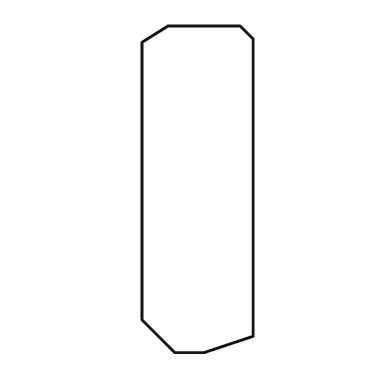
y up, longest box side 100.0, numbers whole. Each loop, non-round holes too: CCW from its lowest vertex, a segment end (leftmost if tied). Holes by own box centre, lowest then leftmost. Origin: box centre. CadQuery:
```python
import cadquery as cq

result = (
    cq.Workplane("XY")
    .moveTo(-7.0, -50.0)
    .lineTo(2.0, -50.0)
    .lineTo(17.0, -45.0)
    .lineTo(17.0, 46.0)
    .lineTo(13.0, 50.0)
    .lineTo(-9.0, 50.0)
    .lineTo(-17.0, 45.0)
    .lineTo(-17.0, -40.0)
    .close()
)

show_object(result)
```